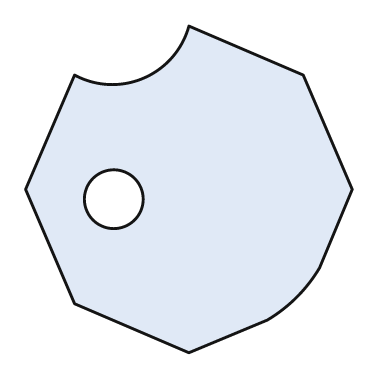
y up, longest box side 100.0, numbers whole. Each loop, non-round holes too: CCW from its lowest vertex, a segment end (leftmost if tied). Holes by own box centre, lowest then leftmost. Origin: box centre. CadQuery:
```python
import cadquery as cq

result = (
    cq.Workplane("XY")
    .moveTo(0.0, -50.0)
    .lineTo(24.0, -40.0)
    .threePointArc((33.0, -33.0), (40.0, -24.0))
    .lineTo(50.0, 0.0)
    .lineTo(35.0, 35.0)
    .lineTo(0.0, 50.0)
    .threePointArc((-14.0, 34.0), (-35.0, 35.0))
    .lineTo(-50.0, 0.0)
    .lineTo(-35.0, -35.0)
    .close()
    .moveTo(-23.0, -3.0)
    .circle(9.0)
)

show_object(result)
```